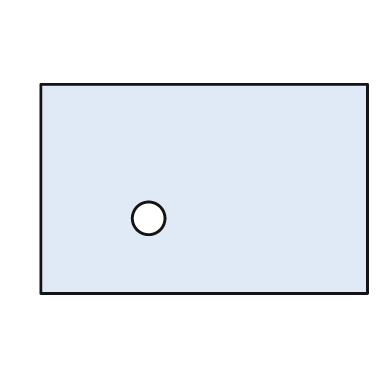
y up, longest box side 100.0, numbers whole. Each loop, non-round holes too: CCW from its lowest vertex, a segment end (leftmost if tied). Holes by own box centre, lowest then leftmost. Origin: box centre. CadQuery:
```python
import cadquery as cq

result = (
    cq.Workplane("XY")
    .moveTo(-50.0, -32.0)
    .lineTo(50.0, -32.0)
    .lineTo(50.0, 32.0)
    .lineTo(-50.0, 32.0)
    .close()
    .moveTo(-17.0, -9.0)
    .circle(5.0)
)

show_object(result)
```